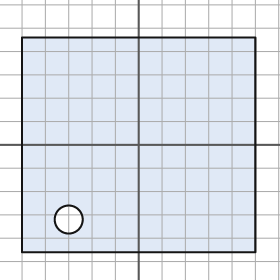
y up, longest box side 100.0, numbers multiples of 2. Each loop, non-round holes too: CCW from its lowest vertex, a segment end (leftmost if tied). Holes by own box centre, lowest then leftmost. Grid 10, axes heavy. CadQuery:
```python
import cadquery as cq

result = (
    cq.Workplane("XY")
    .moveTo(-50.0, -46.0)
    .lineTo(50.0, -46.0)
    .lineTo(50.0, 46.0)
    .lineTo(-50.0, 46.0)
    .close()
    .moveTo(-30.0, -32.0)
    .circle(6.0)
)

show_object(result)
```